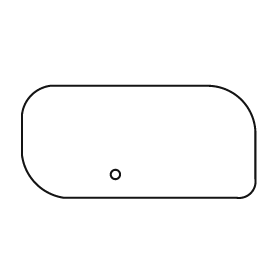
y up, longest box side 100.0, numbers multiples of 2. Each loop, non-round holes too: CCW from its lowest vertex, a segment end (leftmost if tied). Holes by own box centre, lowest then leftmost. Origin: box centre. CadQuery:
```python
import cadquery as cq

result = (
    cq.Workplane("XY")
    .moveTo(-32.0, -24.0)
    .lineTo(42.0, -24.0)
    .threePointArc((48.0, -22.0), (50.0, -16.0))
    .lineTo(50.0, 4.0)
    .threePointArc((44.0, 18.0), (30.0, 24.0))
    .lineTo(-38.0, 24.0)
    .threePointArc((-46.0, 20.0), (-50.0, 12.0))
    .lineTo(-50.0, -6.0)
    .threePointArc((-44.0, -18.0), (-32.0, -24.0))
    .close()
    .moveTo(-10.0, -14.0)
    .circle(2.0)
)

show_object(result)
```